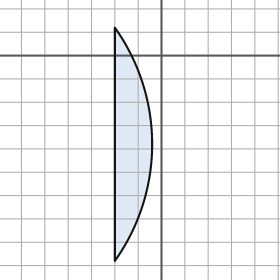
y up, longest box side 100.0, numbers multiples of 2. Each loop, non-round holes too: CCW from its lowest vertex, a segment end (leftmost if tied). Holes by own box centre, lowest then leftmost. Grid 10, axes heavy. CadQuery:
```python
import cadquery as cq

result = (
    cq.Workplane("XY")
    .moveTo(-20.0, -88.0)
    .threePointArc((-4.0, -38.0), (-20.0, 12.0))
    .close()
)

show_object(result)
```